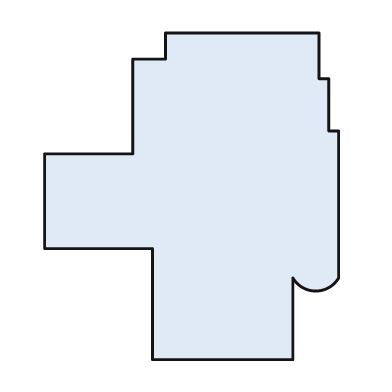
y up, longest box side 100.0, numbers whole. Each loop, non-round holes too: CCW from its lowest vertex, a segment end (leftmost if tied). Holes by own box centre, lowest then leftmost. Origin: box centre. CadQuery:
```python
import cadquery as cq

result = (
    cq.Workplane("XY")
    .moveTo(-12.0, -50.0)
    .lineTo(31.0, -50.0)
    .lineTo(31.0, -25.0)
    .threePointArc((38.0, -29.0), (45.0, -25.0))
    .lineTo(45.0, 20.0)
    .lineTo(42.0, 20.0)
    .lineTo(42.0, 36.0)
    .lineTo(39.0, 36.0)
    .lineTo(39.0, 50.0)
    .lineTo(-8.0, 50.0)
    .lineTo(-8.0, 42.0)
    .lineTo(-18.0, 42.0)
    .lineTo(-18.0, 13.0)
    .lineTo(-45.0, 13.0)
    .lineTo(-45.0, -16.0)
    .lineTo(-12.0, -16.0)
    .close()
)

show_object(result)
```